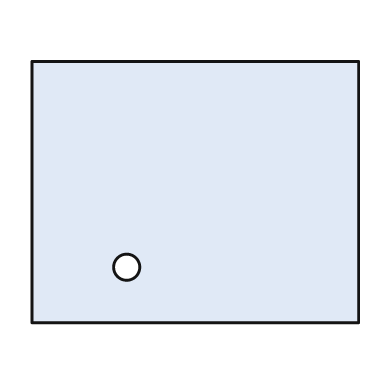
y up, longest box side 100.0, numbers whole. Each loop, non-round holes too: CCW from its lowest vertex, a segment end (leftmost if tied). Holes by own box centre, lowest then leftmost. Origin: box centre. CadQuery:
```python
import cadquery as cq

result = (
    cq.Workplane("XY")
    .moveTo(-50.0, -40.0)
    .lineTo(50.0, -40.0)
    .lineTo(50.0, 40.0)
    .lineTo(-50.0, 40.0)
    .close()
    .moveTo(-21.0, -23.0)
    .circle(4.0)
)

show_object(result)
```